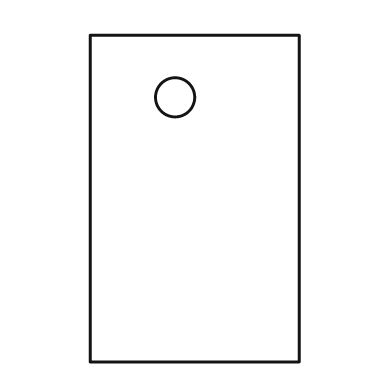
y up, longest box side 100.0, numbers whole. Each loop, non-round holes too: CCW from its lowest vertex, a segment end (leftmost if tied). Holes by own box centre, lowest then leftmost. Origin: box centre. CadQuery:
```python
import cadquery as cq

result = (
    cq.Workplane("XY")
    .moveTo(-32.0, -50.0)
    .lineTo(32.0, -50.0)
    .lineTo(32.0, 50.0)
    .lineTo(-32.0, 50.0)
    .close()
    .moveTo(-6.0, 31.0)
    .circle(6.0)
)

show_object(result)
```